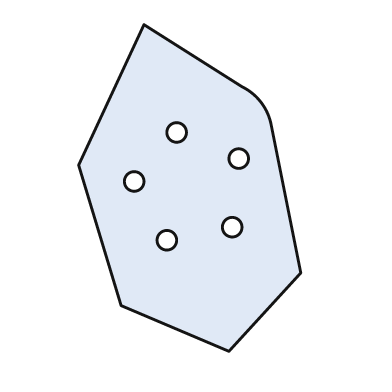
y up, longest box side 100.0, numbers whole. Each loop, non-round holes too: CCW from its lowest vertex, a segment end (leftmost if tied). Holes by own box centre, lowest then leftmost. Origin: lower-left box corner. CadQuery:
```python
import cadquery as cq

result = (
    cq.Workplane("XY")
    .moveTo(46.0, 0.0)
    .lineTo(68.0, 24.0)
    .lineTo(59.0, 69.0)
    .threePointArc((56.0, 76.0), (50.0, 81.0))
    .lineTo(20.0, 100.0)
    .lineTo(0.0, 57.0)
    .lineTo(13.0, 14.0)
    .close()
    .moveTo(27.0, 34.0)
    .circle(3.0)
    .moveTo(47.0, 38.0)
    .circle(3.0)
    .moveTo(17.0, 52.0)
    .circle(3.0)
    .moveTo(49.0, 59.0)
    .circle(3.0)
    .moveTo(30.0, 67.0)
    .circle(3.0)
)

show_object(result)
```